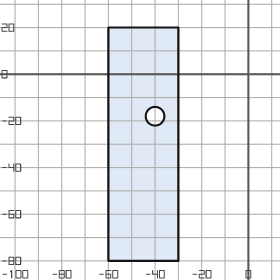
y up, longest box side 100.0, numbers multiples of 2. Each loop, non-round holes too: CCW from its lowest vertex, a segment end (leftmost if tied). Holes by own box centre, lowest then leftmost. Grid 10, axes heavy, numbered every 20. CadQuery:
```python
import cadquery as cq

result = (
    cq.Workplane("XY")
    .moveTo(-60.0, -80.0)
    .lineTo(-30.0, -80.0)
    .lineTo(-30.0, 20.0)
    .lineTo(-60.0, 20.0)
    .close()
    .moveTo(-40.0, -18.0)
    .circle(4.0)
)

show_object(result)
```